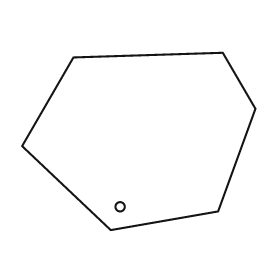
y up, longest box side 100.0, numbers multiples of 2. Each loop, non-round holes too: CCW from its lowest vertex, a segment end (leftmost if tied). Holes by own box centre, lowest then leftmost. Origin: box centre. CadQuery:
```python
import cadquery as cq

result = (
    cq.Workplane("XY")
    .moveTo(-12.0, -38.0)
    .lineTo(34.0, -30.0)
    .lineTo(50.0, 14.0)
    .lineTo(36.0, 38.0)
    .lineTo(-28.0, 36.0)
    .lineTo(-50.0, -2.0)
    .close()
    .moveTo(-8.0, -28.0)
    .circle(2.0)
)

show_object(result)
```